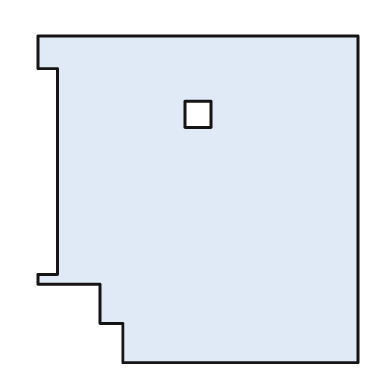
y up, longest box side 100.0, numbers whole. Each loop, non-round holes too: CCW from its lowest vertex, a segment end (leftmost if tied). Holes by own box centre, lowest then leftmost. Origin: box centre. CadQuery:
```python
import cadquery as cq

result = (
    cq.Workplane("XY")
    .moveTo(-23.0, -50.0)
    .lineTo(49.0, -50.0)
    .lineTo(49.0, 50.0)
    .lineTo(-49.0, 50.0)
    .lineTo(-49.0, 40.0)
    .lineTo(-43.0, 40.0)
    .lineTo(-43.0, -23.0)
    .lineTo(-49.0, -23.0)
    .lineTo(-49.0, -26.0)
    .lineTo(-30.0, -26.0)
    .lineTo(-30.0, -38.0)
    .lineTo(-23.0, -38.0)
    .close()
    .moveTo(-4.0, 22.0)
    .lineTo(4.0, 22.0)
    .lineTo(4.0, 30.0)
    .lineTo(-4.0, 30.0)
    .close()
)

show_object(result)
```